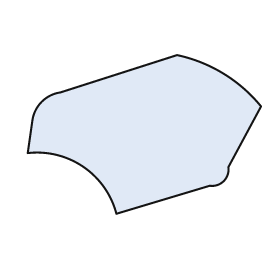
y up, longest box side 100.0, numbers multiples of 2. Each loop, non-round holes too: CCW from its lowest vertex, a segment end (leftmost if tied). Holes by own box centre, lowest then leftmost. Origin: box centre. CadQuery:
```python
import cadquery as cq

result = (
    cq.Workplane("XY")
    .moveTo(-12.0, -34.0)
    .lineTo(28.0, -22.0)
    .threePointArc((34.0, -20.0), (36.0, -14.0))
    .lineTo(50.0, 12.0)
    .threePointArc((34.0, 26.0), (14.0, 34.0))
    .lineTo(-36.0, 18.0)
    .threePointArc((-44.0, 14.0), (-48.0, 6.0))
    .lineTo(-50.0, -8.0)
    .threePointArc((-26.0, -14.0), (-12.0, -34.0))
    .close()
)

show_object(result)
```